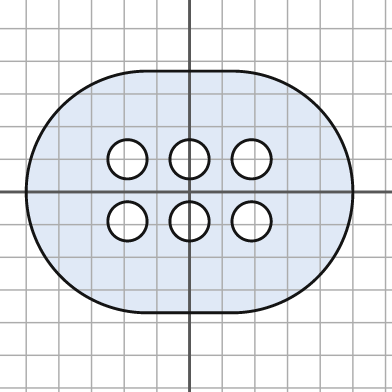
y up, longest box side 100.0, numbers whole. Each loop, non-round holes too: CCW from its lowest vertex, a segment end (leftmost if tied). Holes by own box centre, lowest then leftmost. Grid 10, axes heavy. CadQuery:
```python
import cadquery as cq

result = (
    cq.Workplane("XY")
    .moveTo(-13.0, -37.0)
    .lineTo(13.0, -37.0)
    .threePointArc((50.0, 0.0), (13.0, 37.0))
    .lineTo(-13.0, 37.0)
    .threePointArc((-50.0, 0.0), (-13.0, -37.0))
    .close()
    .moveTo(-19.0, -9.0)
    .circle(6.0)
    .moveTo(0.0, -9.0)
    .circle(6.0)
    .moveTo(19.0, -9.0)
    .circle(6.0)
    .moveTo(-19.0, 10.0)
    .circle(6.0)
    .moveTo(0.0, 10.0)
    .circle(6.0)
    .moveTo(19.0, 10.0)
    .circle(6.0)
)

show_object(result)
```